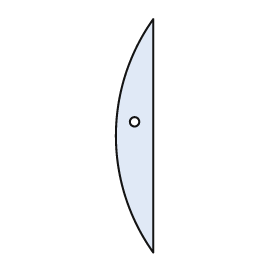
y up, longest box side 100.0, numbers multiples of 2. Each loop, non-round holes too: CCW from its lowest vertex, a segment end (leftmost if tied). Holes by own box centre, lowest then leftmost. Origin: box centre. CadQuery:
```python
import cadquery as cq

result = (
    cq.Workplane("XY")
    .moveTo(8.0, -50.0)
    .lineTo(8.0, 50.0)
    .threePointArc((-8.0, 0.0), (8.0, -50.0))
    .close()
    .moveTo(0.0, 6.0)
    .circle(2.0)
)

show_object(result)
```